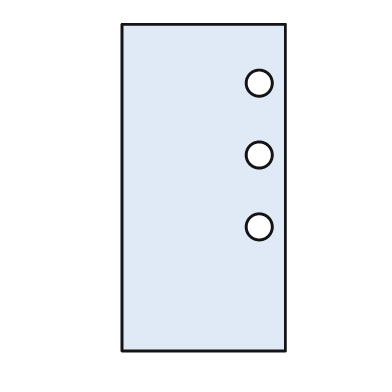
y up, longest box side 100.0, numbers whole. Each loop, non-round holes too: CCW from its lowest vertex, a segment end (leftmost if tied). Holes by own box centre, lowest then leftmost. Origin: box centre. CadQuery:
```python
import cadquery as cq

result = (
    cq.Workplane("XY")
    .moveTo(-25.0, -50.0)
    .lineTo(25.0, -50.0)
    .lineTo(25.0, 50.0)
    .lineTo(-25.0, 50.0)
    .close()
    .moveTo(17.0, -12.0)
    .circle(4.0)
    .moveTo(17.0, 10.0)
    .circle(4.0)
    .moveTo(17.0, 32.0)
    .circle(4.0)
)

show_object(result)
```